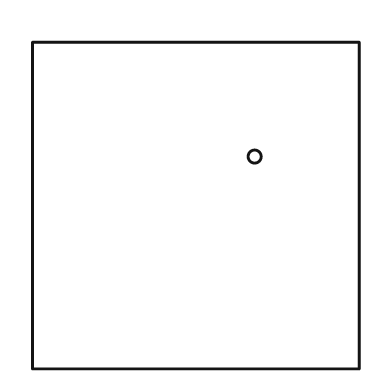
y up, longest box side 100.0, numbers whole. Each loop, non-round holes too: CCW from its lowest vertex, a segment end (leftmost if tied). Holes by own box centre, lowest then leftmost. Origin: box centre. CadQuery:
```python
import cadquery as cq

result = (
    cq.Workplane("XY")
    .moveTo(-50.0, -50.0)
    .lineTo(50.0, -50.0)
    .lineTo(50.0, 50.0)
    .lineTo(-50.0, 50.0)
    .close()
    .moveTo(18.0, 15.0)
    .circle(2.0)
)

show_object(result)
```